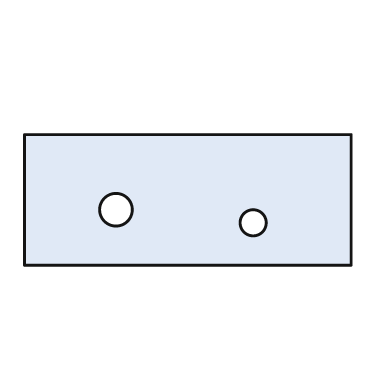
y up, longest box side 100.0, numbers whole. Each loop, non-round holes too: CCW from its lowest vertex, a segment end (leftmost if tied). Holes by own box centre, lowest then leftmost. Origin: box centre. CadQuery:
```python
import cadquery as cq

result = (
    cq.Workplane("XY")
    .moveTo(-50.0, -20.0)
    .lineTo(50.0, -20.0)
    .lineTo(50.0, 20.0)
    .lineTo(-50.0, 20.0)
    .close()
    .moveTo(20.0, -7.0)
    .circle(4.0)
    .moveTo(-22.0, -3.0)
    .circle(5.0)
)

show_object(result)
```